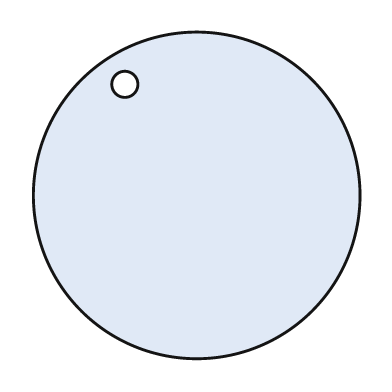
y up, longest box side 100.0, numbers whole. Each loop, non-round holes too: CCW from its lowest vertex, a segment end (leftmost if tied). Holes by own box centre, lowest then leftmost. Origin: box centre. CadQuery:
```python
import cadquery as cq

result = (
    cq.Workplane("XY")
    .moveTo(0.0, 0.0)
    .circle(50.0)
    .moveTo(-22.0, 34.0)
    .circle(4.0)
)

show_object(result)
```